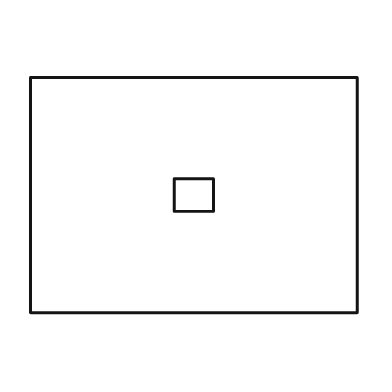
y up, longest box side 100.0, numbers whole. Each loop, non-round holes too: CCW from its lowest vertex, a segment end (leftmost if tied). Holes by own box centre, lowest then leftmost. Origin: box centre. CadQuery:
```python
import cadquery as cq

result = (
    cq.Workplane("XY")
    .moveTo(-50.0, -36.0)
    .lineTo(50.0, -36.0)
    .lineTo(50.0, 36.0)
    .lineTo(-50.0, 36.0)
    .close()
    .moveTo(-6.0, -5.0)
    .lineTo(6.0, -5.0)
    .lineTo(6.0, 5.0)
    .lineTo(-6.0, 5.0)
    .close()
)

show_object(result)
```